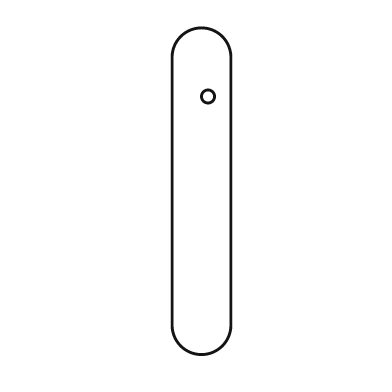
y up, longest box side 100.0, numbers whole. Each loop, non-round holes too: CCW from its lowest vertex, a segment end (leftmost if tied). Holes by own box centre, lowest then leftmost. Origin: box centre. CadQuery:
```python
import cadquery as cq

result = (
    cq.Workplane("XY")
    .moveTo(-9.0, -41.0)
    .threePointArc((0.0, -50.0), (9.0, -41.0))
    .lineTo(9.0, 41.0)
    .threePointArc((0.0, 50.0), (-9.0, 41.0))
    .close()
    .moveTo(2.0, 29.0)
    .circle(2.0)
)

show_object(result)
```